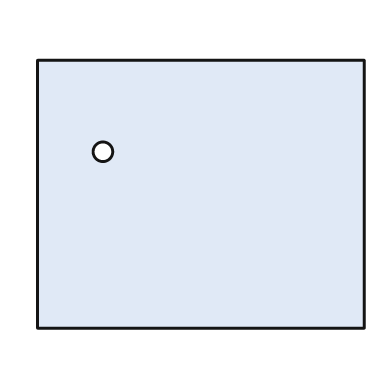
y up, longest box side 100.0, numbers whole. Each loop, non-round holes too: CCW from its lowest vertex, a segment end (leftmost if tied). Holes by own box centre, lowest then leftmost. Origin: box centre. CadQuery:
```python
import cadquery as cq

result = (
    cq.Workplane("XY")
    .moveTo(-50.0, -41.0)
    .lineTo(50.0, -41.0)
    .lineTo(50.0, 41.0)
    .lineTo(-50.0, 41.0)
    .close()
    .moveTo(-30.0, 13.0)
    .circle(3.0)
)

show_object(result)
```